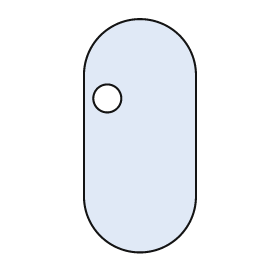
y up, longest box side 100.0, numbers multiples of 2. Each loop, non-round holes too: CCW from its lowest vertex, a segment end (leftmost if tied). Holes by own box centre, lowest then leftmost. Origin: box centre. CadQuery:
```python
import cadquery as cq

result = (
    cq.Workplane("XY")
    .moveTo(-24.0, -26.0)
    .threePointArc((0.0, -50.0), (24.0, -26.0))
    .lineTo(24.0, 26.0)
    .threePointArc((0.0, 50.0), (-24.0, 26.0))
    .close()
    .moveTo(-14.0, 16.0)
    .circle(6.0)
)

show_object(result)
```